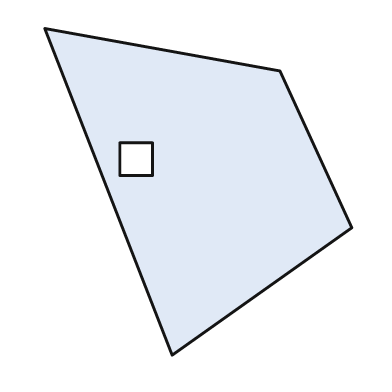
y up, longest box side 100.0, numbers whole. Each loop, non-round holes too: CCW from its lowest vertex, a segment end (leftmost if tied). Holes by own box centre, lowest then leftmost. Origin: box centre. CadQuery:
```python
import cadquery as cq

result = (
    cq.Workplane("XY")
    .moveTo(-8.0, -50.0)
    .lineTo(47.0, -11.0)
    .lineTo(25.0, 37.0)
    .lineTo(-47.0, 50.0)
    .close()
    .moveTo(-24.0, 5.0)
    .lineTo(-14.0, 5.0)
    .lineTo(-14.0, 15.0)
    .lineTo(-24.0, 15.0)
    .close()
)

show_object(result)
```